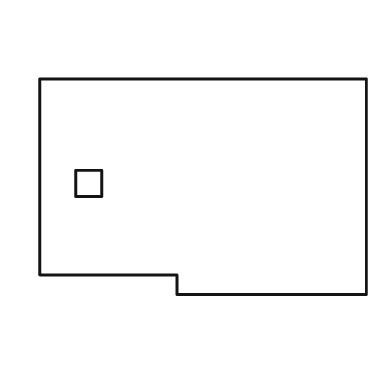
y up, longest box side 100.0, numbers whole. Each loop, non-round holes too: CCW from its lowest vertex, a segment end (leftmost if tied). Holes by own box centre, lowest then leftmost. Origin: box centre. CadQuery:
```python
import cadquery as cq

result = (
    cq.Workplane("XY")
    .moveTo(-8.0, -33.0)
    .lineTo(50.0, -33.0)
    .lineTo(50.0, 33.0)
    .lineTo(-50.0, 33.0)
    .lineTo(-50.0, -27.0)
    .lineTo(-8.0, -27.0)
    .close()
    .moveTo(-39.0, -3.0)
    .lineTo(-31.0, -3.0)
    .lineTo(-31.0, 5.0)
    .lineTo(-39.0, 5.0)
    .close()
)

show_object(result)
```